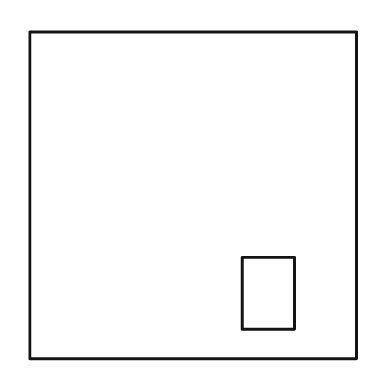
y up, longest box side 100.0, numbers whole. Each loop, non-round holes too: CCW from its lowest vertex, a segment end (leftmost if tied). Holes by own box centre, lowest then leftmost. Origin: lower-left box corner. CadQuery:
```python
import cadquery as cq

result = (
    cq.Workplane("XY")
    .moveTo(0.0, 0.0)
    .lineTo(100.0, 0.0)
    .lineTo(100.0, 100.0)
    .lineTo(0.0, 100.0)
    .close()
    .moveTo(65.0, 9.0)
    .lineTo(81.0, 9.0)
    .lineTo(81.0, 31.0)
    .lineTo(65.0, 31.0)
    .close()
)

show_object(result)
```